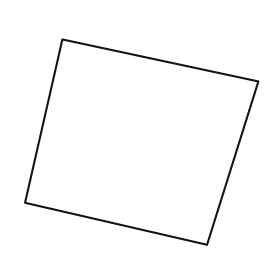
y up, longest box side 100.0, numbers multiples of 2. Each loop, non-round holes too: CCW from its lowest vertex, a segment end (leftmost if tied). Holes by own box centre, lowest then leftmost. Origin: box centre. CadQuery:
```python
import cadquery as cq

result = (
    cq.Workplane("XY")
    .moveTo(28.0, -44.0)
    .lineTo(50.0, 26.0)
    .lineTo(-34.0, 44.0)
    .lineTo(-50.0, -26.0)
    .close()
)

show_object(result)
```